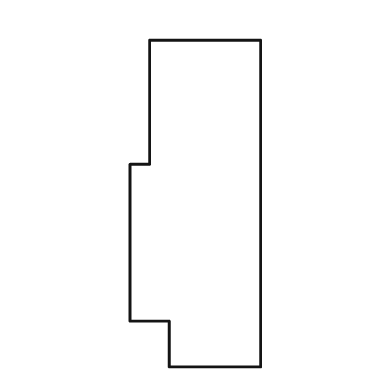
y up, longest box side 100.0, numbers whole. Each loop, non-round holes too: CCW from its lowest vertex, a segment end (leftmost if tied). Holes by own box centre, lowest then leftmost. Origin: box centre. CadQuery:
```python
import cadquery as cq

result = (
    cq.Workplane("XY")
    .moveTo(-8.0, -50.0)
    .lineTo(20.0, -50.0)
    .lineTo(20.0, 50.0)
    .lineTo(-14.0, 50.0)
    .lineTo(-14.0, 12.0)
    .lineTo(-20.0, 12.0)
    .lineTo(-20.0, -36.0)
    .lineTo(-8.0, -36.0)
    .close()
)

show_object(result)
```